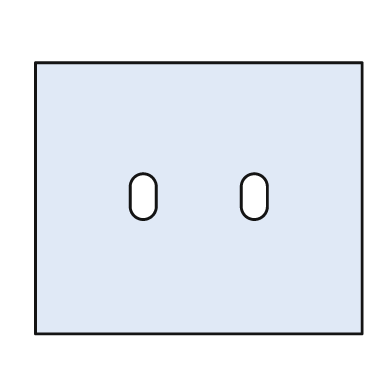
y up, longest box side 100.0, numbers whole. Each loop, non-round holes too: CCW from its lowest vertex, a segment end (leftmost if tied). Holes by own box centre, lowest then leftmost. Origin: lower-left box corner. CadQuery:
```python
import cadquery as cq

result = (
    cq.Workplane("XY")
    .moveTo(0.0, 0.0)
    .lineTo(100.0, 0.0)
    .lineTo(100.0, 83.0)
    .lineTo(0.0, 83.0)
    .close()
    .moveTo(29.0, 39.0)
    .threePointArc((33.0, 35.0), (37.0, 39.0))
    .lineTo(37.0, 45.0)
    .threePointArc((33.0, 49.0), (29.0, 45.0))
    .close()
    .moveTo(63.0, 39.0)
    .threePointArc((67.0, 35.0), (71.0, 39.0))
    .lineTo(71.0, 45.0)
    .threePointArc((67.0, 49.0), (63.0, 45.0))
    .close()
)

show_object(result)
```